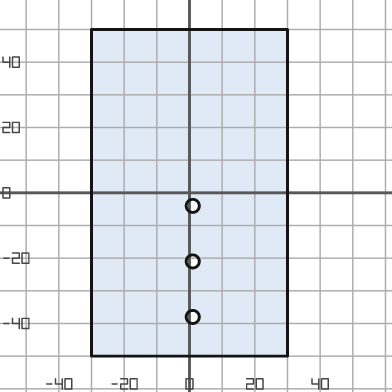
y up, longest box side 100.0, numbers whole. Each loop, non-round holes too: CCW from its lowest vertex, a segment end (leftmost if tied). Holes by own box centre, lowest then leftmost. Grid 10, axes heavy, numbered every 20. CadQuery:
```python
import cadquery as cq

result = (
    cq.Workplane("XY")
    .moveTo(-30.0, -50.0)
    .lineTo(30.0, -50.0)
    .lineTo(30.0, 50.0)
    .lineTo(-30.0, 50.0)
    .close()
    .moveTo(1.0, -38.0)
    .circle(2.0)
    .moveTo(1.0, -21.0)
    .circle(2.0)
    .moveTo(1.0, -4.0)
    .circle(2.0)
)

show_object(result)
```